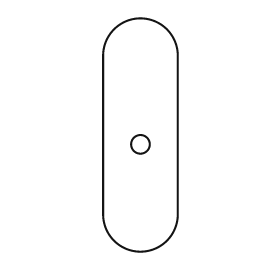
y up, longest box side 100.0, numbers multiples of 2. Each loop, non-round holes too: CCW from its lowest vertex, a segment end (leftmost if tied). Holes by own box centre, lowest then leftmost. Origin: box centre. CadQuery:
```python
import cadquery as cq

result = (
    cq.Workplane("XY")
    .moveTo(-16.0, -34.0)
    .threePointArc((0.0, -50.0), (16.0, -34.0))
    .lineTo(16.0, 34.0)
    .threePointArc((0.0, 50.0), (-16.0, 34.0))
    .close()
    .moveTo(0.0, -4.0)
    .circle(4.0)
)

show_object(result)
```